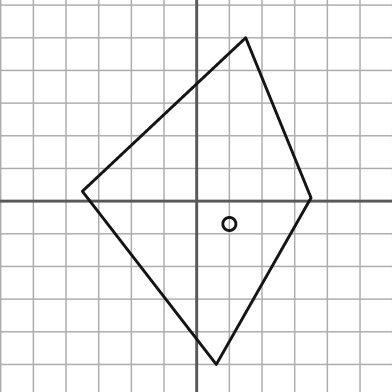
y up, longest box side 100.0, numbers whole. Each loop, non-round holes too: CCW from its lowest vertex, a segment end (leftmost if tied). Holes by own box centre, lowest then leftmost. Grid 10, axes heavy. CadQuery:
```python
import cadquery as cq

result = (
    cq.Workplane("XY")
    .moveTo(6.0, -50.0)
    .lineTo(35.0, 1.0)
    .lineTo(15.0, 50.0)
    .lineTo(-35.0, 3.0)
    .close()
    .moveTo(10.0, -7.0)
    .circle(2.0)
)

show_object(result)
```